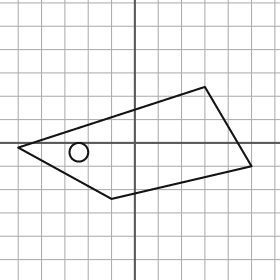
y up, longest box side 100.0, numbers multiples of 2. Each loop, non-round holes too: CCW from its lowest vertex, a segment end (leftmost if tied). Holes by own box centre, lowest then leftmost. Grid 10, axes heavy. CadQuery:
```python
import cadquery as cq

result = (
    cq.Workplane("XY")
    .moveTo(-10.0, -24.0)
    .lineTo(50.0, -10.0)
    .lineTo(30.0, 24.0)
    .lineTo(-50.0, -2.0)
    .close()
    .moveTo(-24.0, -4.0)
    .circle(4.0)
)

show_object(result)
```